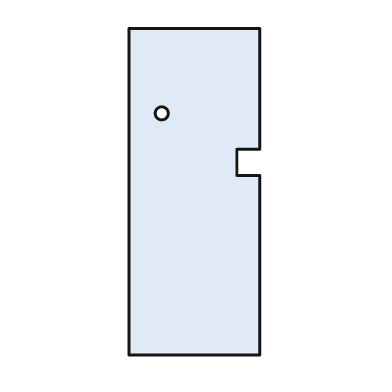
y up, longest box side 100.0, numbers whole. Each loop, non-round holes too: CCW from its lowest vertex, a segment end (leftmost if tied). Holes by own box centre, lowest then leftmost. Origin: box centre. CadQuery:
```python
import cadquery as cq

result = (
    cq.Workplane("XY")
    .moveTo(-20.0, -50.0)
    .lineTo(20.0, -50.0)
    .lineTo(20.0, 5.0)
    .lineTo(13.0, 5.0)
    .lineTo(13.0, 13.0)
    .lineTo(20.0, 13.0)
    .lineTo(20.0, 50.0)
    .lineTo(-20.0, 50.0)
    .close()
    .moveTo(-10.0, 24.0)
    .circle(2.0)
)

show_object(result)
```